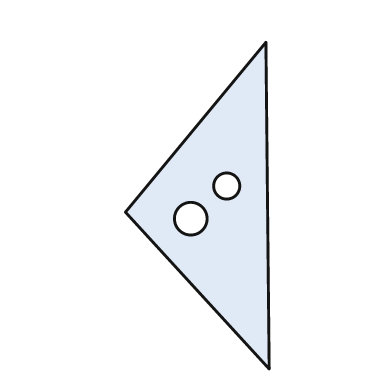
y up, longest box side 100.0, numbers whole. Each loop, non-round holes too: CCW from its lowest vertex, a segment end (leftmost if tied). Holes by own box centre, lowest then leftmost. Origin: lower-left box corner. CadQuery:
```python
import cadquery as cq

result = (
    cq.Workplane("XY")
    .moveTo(44.0, 0.0)
    .lineTo(43.0, 100.0)
    .lineTo(0.0, 48.0)
    .close()
    .moveTo(20.0, 46.0)
    .circle(5.0)
    .moveTo(31.0, 56.0)
    .circle(4.0)
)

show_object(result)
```